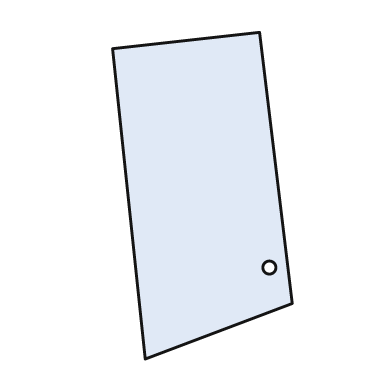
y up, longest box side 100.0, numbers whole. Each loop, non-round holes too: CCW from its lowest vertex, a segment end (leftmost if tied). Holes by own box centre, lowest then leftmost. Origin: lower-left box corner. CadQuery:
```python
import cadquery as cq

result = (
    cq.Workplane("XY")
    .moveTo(10.0, 0.0)
    .lineTo(55.0, 17.0)
    .lineTo(45.0, 100.0)
    .lineTo(0.0, 95.0)
    .close()
    .moveTo(48.0, 28.0)
    .circle(2.0)
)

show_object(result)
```